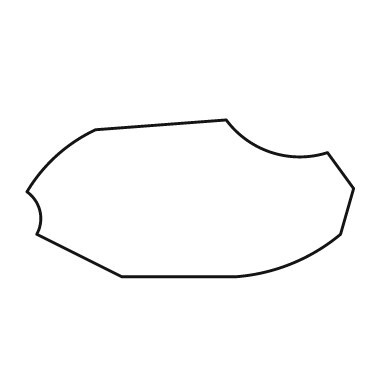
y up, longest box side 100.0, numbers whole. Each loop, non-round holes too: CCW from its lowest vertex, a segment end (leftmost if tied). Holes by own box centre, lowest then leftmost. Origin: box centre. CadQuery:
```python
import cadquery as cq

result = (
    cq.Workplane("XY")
    .moveTo(-21.0, -24.0)
    .lineTo(14.0, -24.0)
    .threePointArc((31.0, -20.0), (46.0, -11.0))
    .lineTo(50.0, 3.0)
    .lineTo(42.0, 14.0)
    .threePointArc((25.0, 14.0), (11.0, 24.0))
    .lineTo(-29.0, 21.0)
    .threePointArc((-41.0, 13.0), (-50.0, 2.0))
    .threePointArc((-46.0, -4.0), (-47.0, -11.0))
    .close()
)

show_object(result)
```